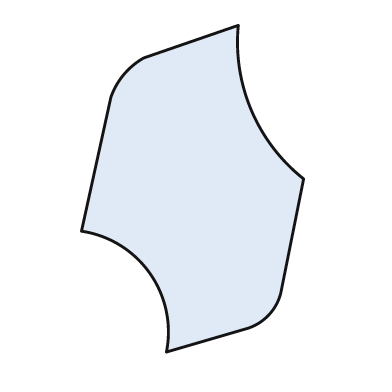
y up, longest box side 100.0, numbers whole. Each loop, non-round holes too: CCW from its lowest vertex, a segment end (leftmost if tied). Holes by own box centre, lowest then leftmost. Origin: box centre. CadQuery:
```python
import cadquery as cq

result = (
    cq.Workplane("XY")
    .moveTo(-8.0, -50.0)
    .lineTo(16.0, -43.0)
    .threePointArc((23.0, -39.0), (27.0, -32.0))
    .lineTo(34.0, 3.0)
    .threePointArc((18.0, 24.0), (14.0, 50.0))
    .lineTo(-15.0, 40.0)
    .threePointArc((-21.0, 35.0), (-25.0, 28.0))
    .lineTo(-34.0, -13.0)
    .threePointArc((-13.0, -26.0), (-8.0, -50.0))
    .close()
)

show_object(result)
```